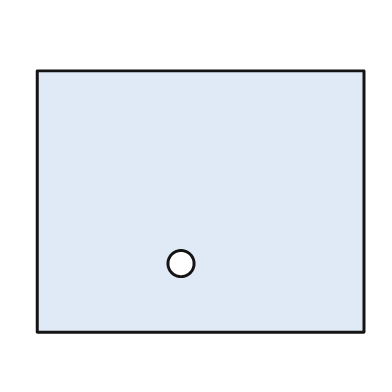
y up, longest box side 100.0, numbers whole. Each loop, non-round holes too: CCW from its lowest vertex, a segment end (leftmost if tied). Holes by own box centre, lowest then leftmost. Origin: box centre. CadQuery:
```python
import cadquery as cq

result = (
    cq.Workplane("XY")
    .moveTo(-50.0, -40.0)
    .lineTo(50.0, -40.0)
    .lineTo(50.0, 40.0)
    .lineTo(-50.0, 40.0)
    .close()
    .moveTo(-6.0, -19.0)
    .circle(4.0)
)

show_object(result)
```